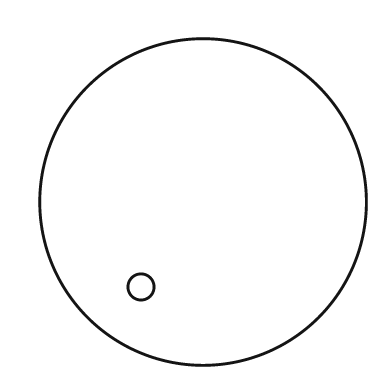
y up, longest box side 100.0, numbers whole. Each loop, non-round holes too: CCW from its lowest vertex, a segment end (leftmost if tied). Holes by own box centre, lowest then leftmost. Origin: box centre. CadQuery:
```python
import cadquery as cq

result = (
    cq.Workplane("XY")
    .moveTo(0.0, 0.0)
    .circle(50.0)
    .moveTo(-19.0, -26.0)
    .circle(4.0)
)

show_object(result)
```